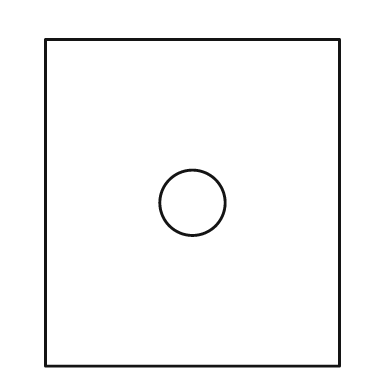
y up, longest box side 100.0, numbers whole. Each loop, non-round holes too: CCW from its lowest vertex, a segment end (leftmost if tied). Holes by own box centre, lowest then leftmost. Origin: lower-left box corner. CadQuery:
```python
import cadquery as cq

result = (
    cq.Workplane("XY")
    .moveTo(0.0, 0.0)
    .lineTo(90.0, 0.0)
    .lineTo(90.0, 100.0)
    .lineTo(0.0, 100.0)
    .close()
    .moveTo(45.0, 50.0)
    .circle(10.0)
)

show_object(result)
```